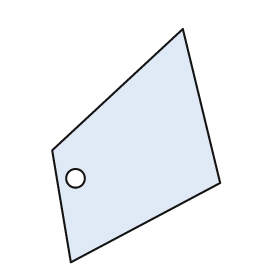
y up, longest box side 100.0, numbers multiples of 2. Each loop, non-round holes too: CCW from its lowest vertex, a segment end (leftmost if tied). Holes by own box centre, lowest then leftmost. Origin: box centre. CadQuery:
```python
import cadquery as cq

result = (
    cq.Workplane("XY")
    .moveTo(-28.0, -50.0)
    .lineTo(36.0, -16.0)
    .lineTo(20.0, 50.0)
    .lineTo(-36.0, -2.0)
    .close()
    .moveTo(-26.0, -14.0)
    .circle(4.0)
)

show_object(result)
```